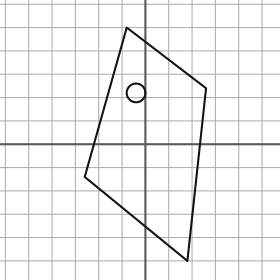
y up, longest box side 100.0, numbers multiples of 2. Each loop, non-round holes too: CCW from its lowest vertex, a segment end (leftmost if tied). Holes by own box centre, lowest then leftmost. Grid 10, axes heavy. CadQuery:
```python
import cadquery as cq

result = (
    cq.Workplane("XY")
    .moveTo(18.0, -50.0)
    .lineTo(26.0, 24.0)
    .lineTo(-8.0, 50.0)
    .lineTo(-26.0, -14.0)
    .close()
    .moveTo(-4.0, 22.0)
    .circle(4.0)
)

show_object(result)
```